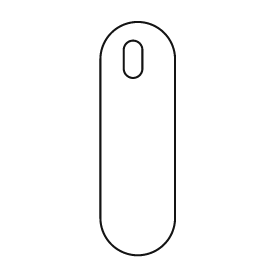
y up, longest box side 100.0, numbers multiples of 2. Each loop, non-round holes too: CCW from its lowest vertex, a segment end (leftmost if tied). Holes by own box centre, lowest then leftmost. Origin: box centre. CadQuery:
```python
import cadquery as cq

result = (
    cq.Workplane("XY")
    .moveTo(-16.0, -34.0)
    .threePointArc((0.0, -50.0), (16.0, -34.0))
    .lineTo(16.0, 34.0)
    .threePointArc((0.0, 50.0), (-16.0, 34.0))
    .close()
    .moveTo(-6.0, 30.0)
    .threePointArc((-2.0, 26.0), (2.0, 30.0))
    .lineTo(2.0, 38.0)
    .threePointArc((-2.0, 42.0), (-6.0, 38.0))
    .close()
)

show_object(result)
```